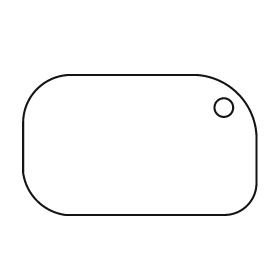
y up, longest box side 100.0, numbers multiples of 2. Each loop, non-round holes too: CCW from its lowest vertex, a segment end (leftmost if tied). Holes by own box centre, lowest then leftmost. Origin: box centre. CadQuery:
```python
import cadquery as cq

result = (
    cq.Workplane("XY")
    .moveTo(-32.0, -30.0)
    .lineTo(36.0, -30.0)
    .threePointArc((46.0, -26.0), (50.0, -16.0))
    .lineTo(50.0, 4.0)
    .threePointArc((42.0, 22.0), (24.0, 30.0))
    .lineTo(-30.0, 30.0)
    .threePointArc((-44.0, 24.0), (-50.0, 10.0))
    .lineTo(-50.0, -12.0)
    .threePointArc((-44.0, -24.0), (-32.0, -30.0))
    .close()
    .moveTo(36.0, 16.0)
    .circle(4.0)
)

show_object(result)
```